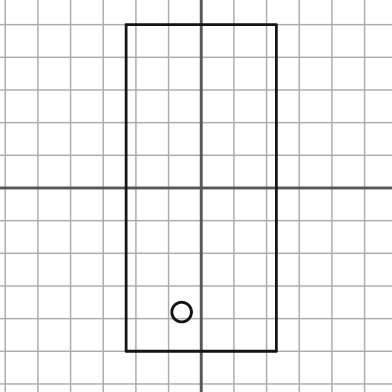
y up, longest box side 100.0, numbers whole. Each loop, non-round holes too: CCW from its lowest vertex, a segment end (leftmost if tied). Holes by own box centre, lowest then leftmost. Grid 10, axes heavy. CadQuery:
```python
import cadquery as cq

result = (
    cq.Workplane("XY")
    .moveTo(-23.0, -50.0)
    .lineTo(23.0, -50.0)
    .lineTo(23.0, 50.0)
    .lineTo(-23.0, 50.0)
    .close()
    .moveTo(-6.0, -38.0)
    .circle(3.0)
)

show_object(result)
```